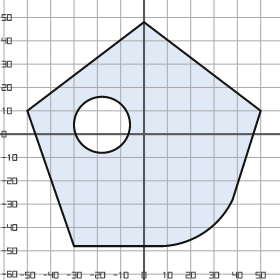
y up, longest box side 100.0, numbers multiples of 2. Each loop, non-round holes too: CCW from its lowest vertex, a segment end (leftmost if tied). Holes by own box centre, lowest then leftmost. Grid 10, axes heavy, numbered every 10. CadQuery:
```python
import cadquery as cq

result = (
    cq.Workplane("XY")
    .moveTo(-30.0, -48.0)
    .lineTo(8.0, -48.0)
    .threePointArc((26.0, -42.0), (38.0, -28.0))
    .lineTo(50.0, 10.0)
    .lineTo(0.0, 48.0)
    .lineTo(-50.0, 10.0)
    .close()
    .moveTo(-18.0, 4.0)
    .circle(12.0)
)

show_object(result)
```